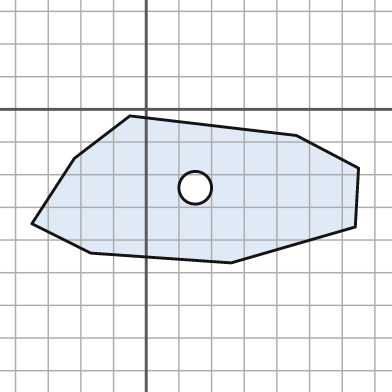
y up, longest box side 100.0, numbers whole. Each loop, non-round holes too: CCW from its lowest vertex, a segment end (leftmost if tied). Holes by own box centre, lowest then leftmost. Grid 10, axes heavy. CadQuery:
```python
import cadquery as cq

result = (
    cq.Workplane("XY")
    .moveTo(26.0, -47.0)
    .lineTo(64.0, -36.0)
    .lineTo(65.0, -18.0)
    .lineTo(46.0, -8.0)
    .lineTo(-5.0, -2.0)
    .lineTo(-22.0, -15.0)
    .lineTo(-35.0, -35.0)
    .lineTo(-17.0, -44.0)
    .close()
    .moveTo(15.0, -24.0)
    .circle(5.0)
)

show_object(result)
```